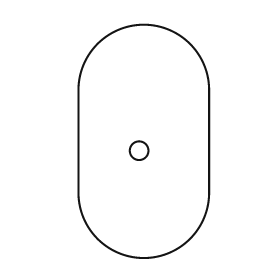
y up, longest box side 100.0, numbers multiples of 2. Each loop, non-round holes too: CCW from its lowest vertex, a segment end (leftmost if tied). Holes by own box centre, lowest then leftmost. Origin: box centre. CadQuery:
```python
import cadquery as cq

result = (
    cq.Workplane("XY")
    .moveTo(-28.0, -22.0)
    .threePointArc((0.0, -50.0), (28.0, -22.0))
    .lineTo(28.0, 22.0)
    .threePointArc((0.0, 50.0), (-28.0, 22.0))
    .close()
    .moveTo(-2.0, -4.0)
    .circle(4.0)
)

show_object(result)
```